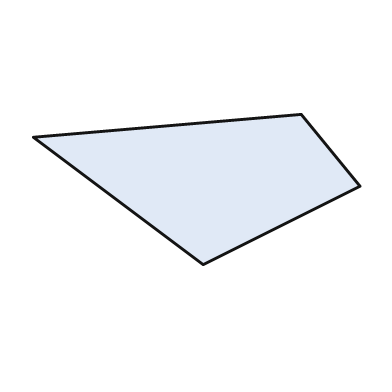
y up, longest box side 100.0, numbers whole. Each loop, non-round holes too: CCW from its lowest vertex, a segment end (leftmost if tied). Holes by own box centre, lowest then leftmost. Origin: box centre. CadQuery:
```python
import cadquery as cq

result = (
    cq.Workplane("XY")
    .moveTo(2.0, -23.0)
    .lineTo(50.0, 1.0)
    .lineTo(32.0, 23.0)
    .lineTo(-50.0, 16.0)
    .close()
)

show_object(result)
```